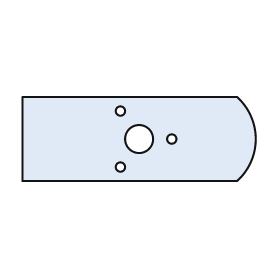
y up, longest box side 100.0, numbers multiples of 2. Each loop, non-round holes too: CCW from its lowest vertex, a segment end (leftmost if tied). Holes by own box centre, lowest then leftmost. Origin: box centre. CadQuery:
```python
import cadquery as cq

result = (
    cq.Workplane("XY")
    .moveTo(-50.0, -18.0)
    .lineTo(42.0, -18.0)
    .threePointArc((50.0, 0.0), (42.0, 18.0))
    .lineTo(-50.0, 18.0)
    .close()
    .moveTo(-8.0, -12.0)
    .circle(2.0)
    .moveTo(0.0, 0.0)
    .circle(6.0)
    .moveTo(14.0, 0.0)
    .circle(2.0)
    .moveTo(-8.0, 12.0)
    .circle(2.0)
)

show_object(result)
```